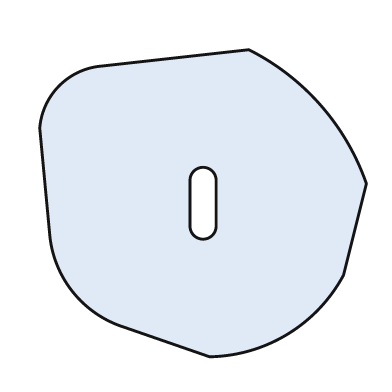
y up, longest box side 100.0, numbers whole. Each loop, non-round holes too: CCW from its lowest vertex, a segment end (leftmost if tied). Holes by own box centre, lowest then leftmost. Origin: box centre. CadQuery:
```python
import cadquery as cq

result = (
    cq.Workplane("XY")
    .moveTo(2.0, -47.0)
    .threePointArc((26.0, -40.0), (43.0, -22.0))
    .lineTo(50.0, 6.0)
    .threePointArc((36.0, 30.0), (14.0, 47.0))
    .lineTo(-31.0, 42.0)
    .threePointArc((-44.0, 36.0), (-50.0, 23.0))
    .lineTo(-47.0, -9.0)
    .threePointArc((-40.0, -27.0), (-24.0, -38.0))
    .close()
    .moveTo(-4.0, -7.0)
    .threePointArc((0.0, -11.0), (4.0, -7.0))
    .lineTo(4.0, 7.0)
    .threePointArc((0.0, 11.0), (-4.0, 7.0))
    .close()
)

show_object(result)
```